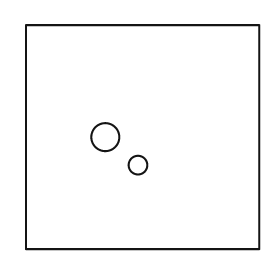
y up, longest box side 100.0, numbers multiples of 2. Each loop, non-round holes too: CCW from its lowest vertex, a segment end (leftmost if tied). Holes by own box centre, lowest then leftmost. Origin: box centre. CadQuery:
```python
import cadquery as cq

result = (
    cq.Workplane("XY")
    .moveTo(-50.0, -48.0)
    .lineTo(50.0, -48.0)
    .lineTo(50.0, 48.0)
    .lineTo(-50.0, 48.0)
    .close()
    .moveTo(-2.0, -12.0)
    .circle(4.0)
    .moveTo(-16.0, 0.0)
    .circle(6.0)
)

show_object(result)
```